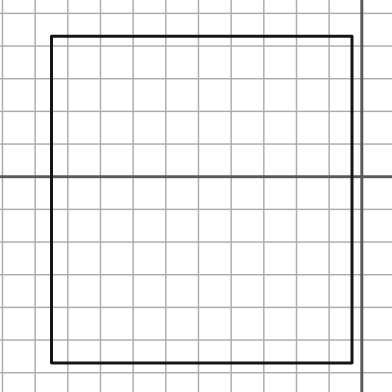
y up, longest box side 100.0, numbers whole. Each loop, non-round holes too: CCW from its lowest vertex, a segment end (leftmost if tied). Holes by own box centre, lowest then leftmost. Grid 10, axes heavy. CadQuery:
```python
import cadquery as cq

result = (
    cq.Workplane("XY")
    .moveTo(-95.0, -57.0)
    .lineTo(-3.0, -57.0)
    .lineTo(-3.0, 43.0)
    .lineTo(-95.0, 43.0)
    .close()
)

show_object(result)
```